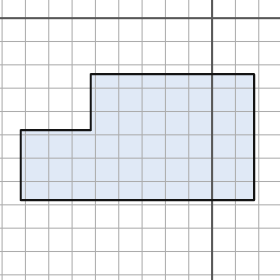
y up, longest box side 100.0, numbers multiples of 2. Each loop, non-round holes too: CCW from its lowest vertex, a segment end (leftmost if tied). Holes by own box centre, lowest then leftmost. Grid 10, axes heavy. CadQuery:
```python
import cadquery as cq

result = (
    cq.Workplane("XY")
    .moveTo(-82.0, -78.0)
    .lineTo(18.0, -78.0)
    .lineTo(18.0, -24.0)
    .lineTo(-52.0, -24.0)
    .lineTo(-52.0, -48.0)
    .lineTo(-82.0, -48.0)
    .close()
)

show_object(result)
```